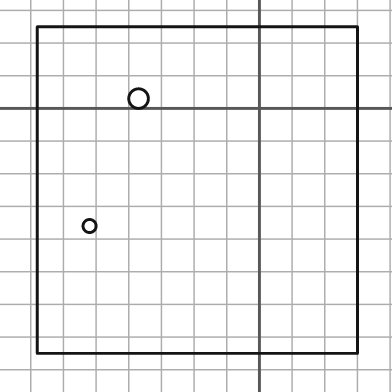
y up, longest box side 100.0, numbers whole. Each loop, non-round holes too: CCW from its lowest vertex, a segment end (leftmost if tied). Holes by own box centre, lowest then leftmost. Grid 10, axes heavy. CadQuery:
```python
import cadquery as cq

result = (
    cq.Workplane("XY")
    .moveTo(-68.0, -75.0)
    .lineTo(30.0, -75.0)
    .lineTo(30.0, 25.0)
    .lineTo(-68.0, 25.0)
    .close()
    .moveTo(-52.0, -36.0)
    .circle(2.0)
    .moveTo(-37.0, 3.0)
    .circle(3.0)
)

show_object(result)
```